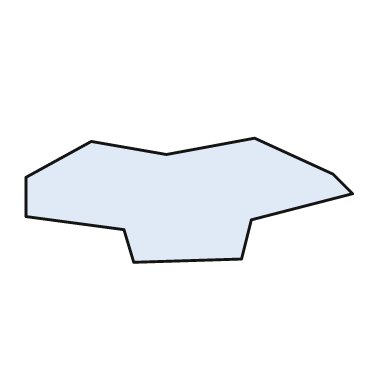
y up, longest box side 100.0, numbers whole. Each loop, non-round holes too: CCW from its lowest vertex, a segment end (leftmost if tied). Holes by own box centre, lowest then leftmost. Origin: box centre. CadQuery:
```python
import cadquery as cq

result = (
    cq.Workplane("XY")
    .moveTo(-17.0, -19.0)
    .lineTo(16.0, -18.0)
    .lineTo(19.0, -6.0)
    .lineTo(50.0, 2.0)
    .lineTo(44.0, 8.0)
    .lineTo(20.0, 19.0)
    .lineTo(-7.0, 14.0)
    .lineTo(-30.0, 18.0)
    .lineTo(-50.0, 7.0)
    .lineTo(-50.0, -5.0)
    .lineTo(-20.0, -9.0)
    .close()
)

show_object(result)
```